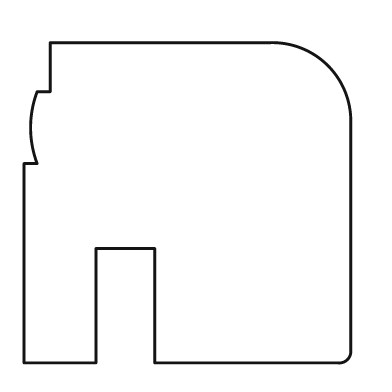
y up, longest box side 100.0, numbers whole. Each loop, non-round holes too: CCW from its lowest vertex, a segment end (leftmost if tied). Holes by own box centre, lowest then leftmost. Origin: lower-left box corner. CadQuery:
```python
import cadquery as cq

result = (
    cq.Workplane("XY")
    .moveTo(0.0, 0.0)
    .lineTo(22.0, 0.0)
    .lineTo(22.0, 35.0)
    .lineTo(40.0, 35.0)
    .lineTo(40.0, 0.0)
    .lineTo(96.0, 0.0)
    .threePointArc((99.0, 1.0), (100.0, 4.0))
    .lineTo(100.0, 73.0)
    .threePointArc((93.0, 91.0), (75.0, 98.0))
    .lineTo(8.0, 98.0)
    .lineTo(8.0, 83.0)
    .lineTo(4.0, 83.0)
    .threePointArc((2.0, 72.0), (4.0, 61.0))
    .lineTo(0.0, 61.0)
    .close()
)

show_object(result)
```